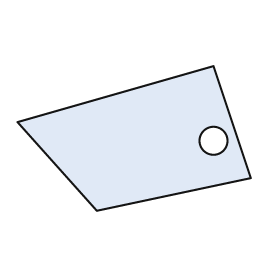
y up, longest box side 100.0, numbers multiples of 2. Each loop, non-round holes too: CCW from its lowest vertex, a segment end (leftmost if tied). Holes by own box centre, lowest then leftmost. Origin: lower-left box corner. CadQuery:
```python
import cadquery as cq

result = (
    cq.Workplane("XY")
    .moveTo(34.0, 0.0)
    .lineTo(100.0, 14.0)
    .lineTo(84.0, 62.0)
    .lineTo(0.0, 38.0)
    .close()
    .moveTo(84.0, 30.0)
    .circle(6.0)
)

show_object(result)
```